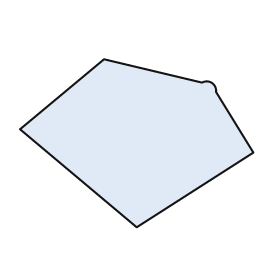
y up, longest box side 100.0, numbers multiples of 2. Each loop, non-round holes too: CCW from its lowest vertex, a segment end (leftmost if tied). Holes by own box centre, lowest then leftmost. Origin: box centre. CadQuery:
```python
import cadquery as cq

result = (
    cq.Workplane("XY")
    .moveTo(0.0, -36.0)
    .lineTo(50.0, -4.0)
    .lineTo(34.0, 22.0)
    .threePointArc((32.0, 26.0), (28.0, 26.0))
    .lineTo(-14.0, 36.0)
    .lineTo(-50.0, 6.0)
    .close()
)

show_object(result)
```